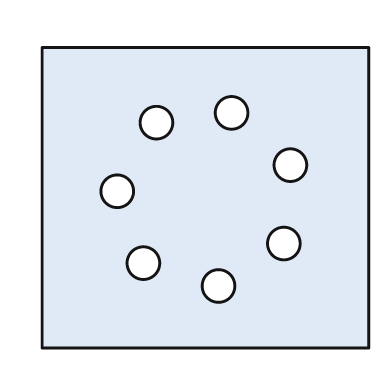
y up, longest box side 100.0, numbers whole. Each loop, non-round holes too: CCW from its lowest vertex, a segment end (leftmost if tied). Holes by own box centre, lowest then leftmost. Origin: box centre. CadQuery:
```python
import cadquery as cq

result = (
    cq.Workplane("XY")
    .moveTo(-50.0, -46.0)
    .lineTo(50.0, -46.0)
    .lineTo(50.0, 46.0)
    .lineTo(-50.0, 46.0)
    .close()
    .moveTo(4.0, -27.0)
    .circle(5.0)
    .moveTo(-19.0, -20.0)
    .circle(5.0)
    .moveTo(24.0, -14.0)
    .circle(5.0)
    .moveTo(-27.0, 2.0)
    .circle(5.0)
    .moveTo(26.0, 10.0)
    .circle(5.0)
    .moveTo(-15.0, 23.0)
    .circle(5.0)
    .moveTo(8.0, 26.0)
    .circle(5.0)
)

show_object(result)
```